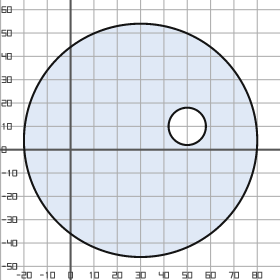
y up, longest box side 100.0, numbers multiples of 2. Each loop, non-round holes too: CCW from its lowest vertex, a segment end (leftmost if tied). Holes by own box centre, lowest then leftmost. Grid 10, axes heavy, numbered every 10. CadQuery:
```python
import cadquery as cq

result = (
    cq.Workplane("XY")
    .moveTo(30.0, 4.0)
    .circle(50.0)
    .moveTo(50.0, 10.0)
    .circle(8.0)
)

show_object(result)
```